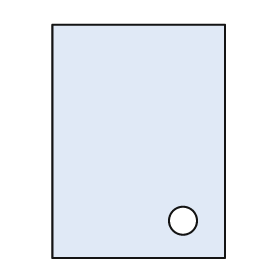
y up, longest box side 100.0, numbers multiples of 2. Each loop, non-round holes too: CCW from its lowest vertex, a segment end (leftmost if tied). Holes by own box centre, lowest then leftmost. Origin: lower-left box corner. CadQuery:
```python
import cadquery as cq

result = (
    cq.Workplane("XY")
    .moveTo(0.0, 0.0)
    .lineTo(74.0, 0.0)
    .lineTo(74.0, 100.0)
    .lineTo(0.0, 100.0)
    .close()
    .moveTo(56.0, 16.0)
    .circle(6.0)
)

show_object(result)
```